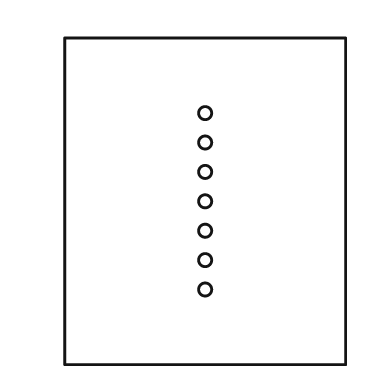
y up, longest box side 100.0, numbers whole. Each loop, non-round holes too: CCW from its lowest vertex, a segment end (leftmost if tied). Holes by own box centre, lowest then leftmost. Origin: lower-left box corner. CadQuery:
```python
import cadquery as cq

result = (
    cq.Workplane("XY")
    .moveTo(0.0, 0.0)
    .lineTo(86.0, 0.0)
    .lineTo(86.0, 100.0)
    .lineTo(0.0, 100.0)
    .close()
    .moveTo(43.0, 23.0)
    .circle(2.0)
    .moveTo(43.0, 32.0)
    .circle(2.0)
    .moveTo(43.0, 41.0)
    .circle(2.0)
    .moveTo(43.0, 50.0)
    .circle(2.0)
    .moveTo(43.0, 59.0)
    .circle(2.0)
    .moveTo(43.0, 68.0)
    .circle(2.0)
    .moveTo(43.0, 77.0)
    .circle(2.0)
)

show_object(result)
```